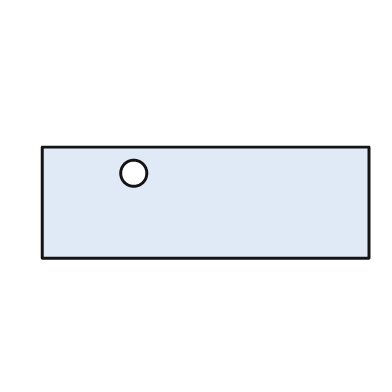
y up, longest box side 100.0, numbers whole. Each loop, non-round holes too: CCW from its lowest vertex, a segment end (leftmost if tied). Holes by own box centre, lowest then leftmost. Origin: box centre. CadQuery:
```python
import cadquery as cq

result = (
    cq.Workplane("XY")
    .moveTo(-50.0, -17.0)
    .lineTo(50.0, -17.0)
    .lineTo(50.0, 17.0)
    .lineTo(-50.0, 17.0)
    .close()
    .moveTo(-22.0, 9.0)
    .circle(4.0)
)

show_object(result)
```